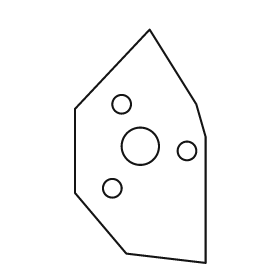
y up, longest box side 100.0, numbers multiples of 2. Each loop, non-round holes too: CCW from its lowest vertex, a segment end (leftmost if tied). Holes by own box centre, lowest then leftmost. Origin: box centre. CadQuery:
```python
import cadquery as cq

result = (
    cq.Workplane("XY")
    .moveTo(28.0, -50.0)
    .lineTo(28.0, 4.0)
    .lineTo(24.0, 18.0)
    .lineTo(4.0, 50.0)
    .lineTo(-28.0, 16.0)
    .lineTo(-28.0, -20.0)
    .lineTo(-6.0, -46.0)
    .close()
    .moveTo(-12.0, -18.0)
    .circle(4.0)
    .moveTo(20.0, -2.0)
    .circle(4.0)
    .moveTo(0.0, 0.0)
    .circle(8.0)
    .moveTo(-8.0, 18.0)
    .circle(4.0)
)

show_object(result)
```